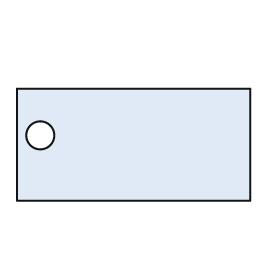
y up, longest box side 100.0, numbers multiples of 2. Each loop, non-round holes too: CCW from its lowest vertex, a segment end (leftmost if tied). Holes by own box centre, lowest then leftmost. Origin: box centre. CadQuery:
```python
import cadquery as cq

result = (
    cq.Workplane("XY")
    .moveTo(-50.0, -24.0)
    .lineTo(50.0, -24.0)
    .lineTo(50.0, 24.0)
    .lineTo(-50.0, 24.0)
    .close()
    .moveTo(-40.0, 4.0)
    .circle(6.0)
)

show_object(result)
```